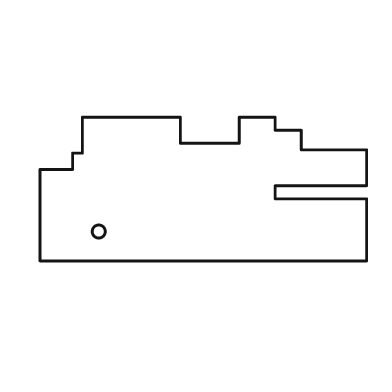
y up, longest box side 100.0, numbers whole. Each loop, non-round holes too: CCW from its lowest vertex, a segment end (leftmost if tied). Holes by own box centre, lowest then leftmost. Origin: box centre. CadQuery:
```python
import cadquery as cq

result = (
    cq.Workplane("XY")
    .moveTo(-50.0, -22.0)
    .lineTo(50.0, -22.0)
    .lineTo(50.0, -3.0)
    .lineTo(22.0, -3.0)
    .lineTo(22.0, 1.0)
    .lineTo(50.0, 1.0)
    .lineTo(50.0, 12.0)
    .lineTo(30.0, 12.0)
    .lineTo(30.0, 18.0)
    .lineTo(22.0, 18.0)
    .lineTo(22.0, 22.0)
    .lineTo(11.0, 22.0)
    .lineTo(11.0, 14.0)
    .lineTo(-7.0, 14.0)
    .lineTo(-7.0, 22.0)
    .lineTo(-37.0, 22.0)
    .lineTo(-37.0, 11.0)
    .lineTo(-40.0, 11.0)
    .lineTo(-40.0, 6.0)
    .lineTo(-50.0, 6.0)
    .close()
    .moveTo(-32.0, -13.0)
    .circle(2.0)
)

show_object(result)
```